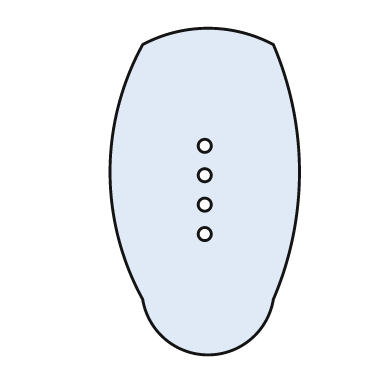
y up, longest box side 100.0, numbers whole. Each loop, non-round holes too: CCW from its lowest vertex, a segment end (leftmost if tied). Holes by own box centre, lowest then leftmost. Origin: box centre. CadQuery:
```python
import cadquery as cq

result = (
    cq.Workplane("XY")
    .moveTo(-19.0, -33.0)
    .threePointArc((1.0, -50.0), (21.0, -33.0))
    .threePointArc((29.0, 6.0), (21.0, 45.0))
    .threePointArc((1.0, 50.0), (-19.0, 45.0))
    .threePointArc((-29.0, 6.0), (-19.0, -33.0))
    .close()
    .moveTo(0.0, -13.0)
    .circle(2.0)
    .moveTo(0.0, -4.0)
    .circle(2.0)
    .moveTo(0.0, 5.0)
    .circle(2.0)
    .moveTo(0.0, 14.0)
    .circle(2.0)
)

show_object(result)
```